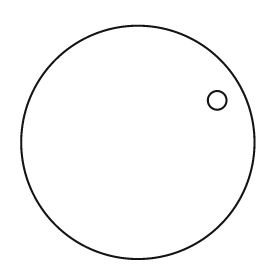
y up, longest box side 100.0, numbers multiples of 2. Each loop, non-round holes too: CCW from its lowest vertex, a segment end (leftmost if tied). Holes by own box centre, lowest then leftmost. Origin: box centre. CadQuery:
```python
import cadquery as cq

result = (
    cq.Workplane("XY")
    .moveTo(0.0, 0.0)
    .circle(50.0)
    .moveTo(34.0, 18.0)
    .circle(4.0)
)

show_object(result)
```